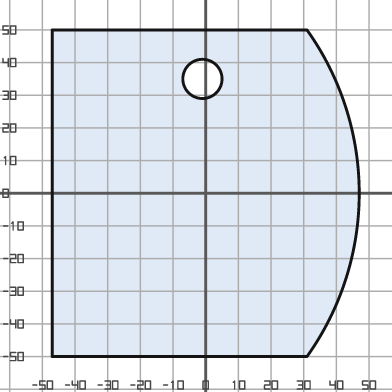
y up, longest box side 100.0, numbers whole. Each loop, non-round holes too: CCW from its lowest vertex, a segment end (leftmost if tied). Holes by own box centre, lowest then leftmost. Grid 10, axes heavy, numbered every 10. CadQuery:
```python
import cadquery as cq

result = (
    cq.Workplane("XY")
    .moveTo(-47.0, -50.0)
    .lineTo(31.0, -50.0)
    .threePointArc((47.0, 0.0), (31.0, 50.0))
    .lineTo(-47.0, 50.0)
    .close()
    .moveTo(-1.0, 35.0)
    .circle(6.0)
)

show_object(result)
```